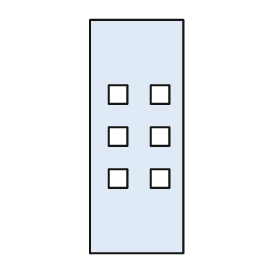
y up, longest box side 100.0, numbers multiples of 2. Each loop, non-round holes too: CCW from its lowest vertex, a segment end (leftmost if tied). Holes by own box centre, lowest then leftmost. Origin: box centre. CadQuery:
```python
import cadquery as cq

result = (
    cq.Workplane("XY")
    .moveTo(-20.0, -50.0)
    .lineTo(20.0, -50.0)
    .lineTo(20.0, 50.0)
    .lineTo(-20.0, 50.0)
    .close()
    .moveTo(-12.0, -22.0)
    .lineTo(-4.0, -22.0)
    .lineTo(-4.0, -14.0)
    .lineTo(-12.0, -14.0)
    .close()
    .moveTo(6.0, -22.0)
    .lineTo(14.0, -22.0)
    .lineTo(14.0, -14.0)
    .lineTo(6.0, -14.0)
    .close()
    .moveTo(-12.0, -4.0)
    .lineTo(-4.0, -4.0)
    .lineTo(-4.0, 4.0)
    .lineTo(-12.0, 4.0)
    .close()
    .moveTo(6.0, -4.0)
    .lineTo(14.0, -4.0)
    .lineTo(14.0, 4.0)
    .lineTo(6.0, 4.0)
    .close()
    .moveTo(-12.0, 14.0)
    .lineTo(-4.0, 14.0)
    .lineTo(-4.0, 22.0)
    .lineTo(-12.0, 22.0)
    .close()
    .moveTo(6.0, 14.0)
    .lineTo(14.0, 14.0)
    .lineTo(14.0, 22.0)
    .lineTo(6.0, 22.0)
    .close()
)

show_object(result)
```